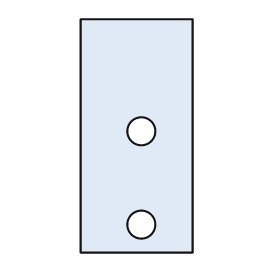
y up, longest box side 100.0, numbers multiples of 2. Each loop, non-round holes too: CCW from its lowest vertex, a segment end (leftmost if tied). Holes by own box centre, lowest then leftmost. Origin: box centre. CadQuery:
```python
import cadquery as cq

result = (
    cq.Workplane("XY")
    .moveTo(-24.0, -50.0)
    .lineTo(24.0, -50.0)
    .lineTo(24.0, 50.0)
    .lineTo(-24.0, 50.0)
    .close()
    .moveTo(2.0, -38.0)
    .circle(6.0)
    .moveTo(2.0, 2.0)
    .circle(6.0)
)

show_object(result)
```